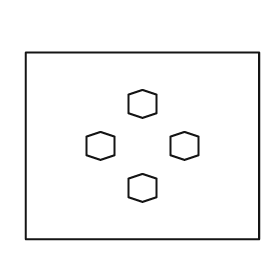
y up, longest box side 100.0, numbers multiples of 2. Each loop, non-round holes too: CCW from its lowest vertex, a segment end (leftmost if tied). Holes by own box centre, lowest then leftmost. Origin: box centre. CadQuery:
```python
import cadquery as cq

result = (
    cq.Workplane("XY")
    .moveTo(-50.0, -40.0)
    .lineTo(50.0, -40.0)
    .lineTo(50.0, 40.0)
    .lineTo(-50.0, 40.0)
    .close()
    .moveTo(0.0, -24.0)
    .lineTo(6.0, -22.0)
    .lineTo(6.0, -14.0)
    .lineTo(0.0, -12.0)
    .lineTo(-6.0, -14.0)
    .lineTo(-6.0, -22.0)
    .close()
    .moveTo(-18.0, -6.0)
    .lineTo(-12.0, -4.0)
    .lineTo(-12.0, 4.0)
    .lineTo(-18.0, 6.0)
    .lineTo(-24.0, 4.0)
    .lineTo(-24.0, -4.0)
    .close()
    .moveTo(18.0, -6.0)
    .lineTo(24.0, -4.0)
    .lineTo(24.0, 4.0)
    .lineTo(18.0, 6.0)
    .lineTo(12.0, 4.0)
    .lineTo(12.0, -4.0)
    .close()
    .moveTo(0.0, 12.0)
    .lineTo(6.0, 14.0)
    .lineTo(6.0, 22.0)
    .lineTo(0.0, 24.0)
    .lineTo(-6.0, 22.0)
    .lineTo(-6.0, 14.0)
    .close()
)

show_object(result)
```